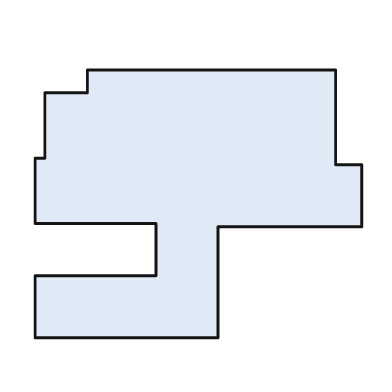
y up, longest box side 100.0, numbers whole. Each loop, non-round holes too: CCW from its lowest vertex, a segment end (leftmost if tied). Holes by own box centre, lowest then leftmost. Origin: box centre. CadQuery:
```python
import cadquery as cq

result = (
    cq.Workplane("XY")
    .moveTo(-50.0, -41.0)
    .lineTo(6.0, -41.0)
    .lineTo(6.0, -7.0)
    .lineTo(50.0, -7.0)
    .lineTo(50.0, 12.0)
    .lineTo(42.0, 12.0)
    .lineTo(42.0, 41.0)
    .lineTo(-34.0, 41.0)
    .lineTo(-34.0, 34.0)
    .lineTo(-47.0, 34.0)
    .lineTo(-47.0, 14.0)
    .lineTo(-50.0, 14.0)
    .lineTo(-50.0, -6.0)
    .lineTo(-13.0, -6.0)
    .lineTo(-13.0, -22.0)
    .lineTo(-50.0, -22.0)
    .close()
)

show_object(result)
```